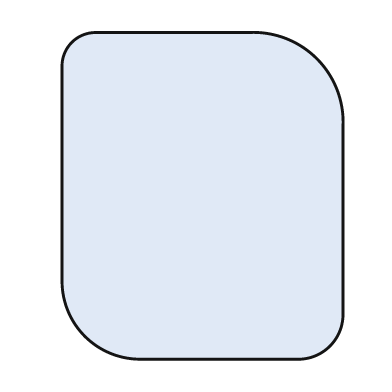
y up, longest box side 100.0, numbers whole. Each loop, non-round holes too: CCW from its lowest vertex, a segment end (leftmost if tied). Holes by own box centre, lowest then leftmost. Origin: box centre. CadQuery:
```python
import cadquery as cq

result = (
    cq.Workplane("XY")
    .moveTo(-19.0, -50.0)
    .lineTo(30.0, -50.0)
    .threePointArc((39.0, -46.0), (43.0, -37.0))
    .lineTo(43.0, 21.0)
    .threePointArc((35.0, 42.0), (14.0, 50.0))
    .lineTo(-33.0, 50.0)
    .threePointArc((-40.0, 47.0), (-43.0, 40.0))
    .lineTo(-43.0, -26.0)
    .threePointArc((-36.0, -43.0), (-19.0, -50.0))
    .close()
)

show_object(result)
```